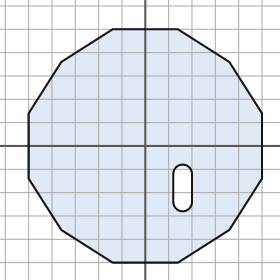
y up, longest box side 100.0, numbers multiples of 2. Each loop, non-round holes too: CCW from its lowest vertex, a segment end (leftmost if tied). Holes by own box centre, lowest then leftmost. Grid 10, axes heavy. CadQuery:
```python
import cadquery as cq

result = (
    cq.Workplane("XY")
    .moveTo(-14.0, -50.0)
    .lineTo(14.0, -50.0)
    .lineTo(36.0, -36.0)
    .lineTo(50.0, -14.0)
    .lineTo(50.0, 14.0)
    .lineTo(36.0, 36.0)
    .lineTo(14.0, 50.0)
    .lineTo(-14.0, 50.0)
    .lineTo(-36.0, 36.0)
    .lineTo(-50.0, 14.0)
    .lineTo(-50.0, -14.0)
    .lineTo(-36.0, -36.0)
    .close()
    .moveTo(12.0, -24.0)
    .threePointArc((16.0, -28.0), (20.0, -24.0))
    .lineTo(20.0, -12.0)
    .threePointArc((16.0, -8.0), (12.0, -12.0))
    .close()
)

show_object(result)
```